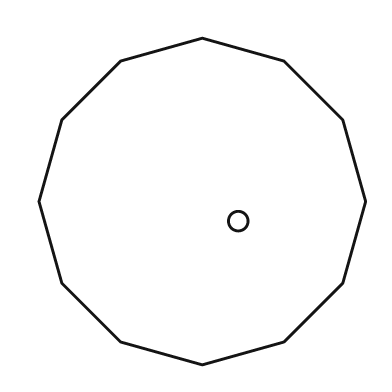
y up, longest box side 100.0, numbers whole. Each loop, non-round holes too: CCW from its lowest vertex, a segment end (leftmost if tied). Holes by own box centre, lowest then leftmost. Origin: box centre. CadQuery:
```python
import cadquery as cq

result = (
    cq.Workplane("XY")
    .moveTo(0.0, -50.0)
    .lineTo(25.0, -43.0)
    .lineTo(43.0, -25.0)
    .lineTo(50.0, 0.0)
    .lineTo(43.0, 25.0)
    .lineTo(25.0, 43.0)
    .lineTo(0.0, 50.0)
    .lineTo(-25.0, 43.0)
    .lineTo(-43.0, 25.0)
    .lineTo(-50.0, 0.0)
    .lineTo(-43.0, -25.0)
    .lineTo(-25.0, -43.0)
    .close()
    .moveTo(11.0, -6.0)
    .circle(3.0)
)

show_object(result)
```